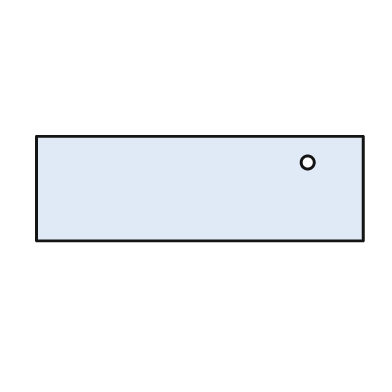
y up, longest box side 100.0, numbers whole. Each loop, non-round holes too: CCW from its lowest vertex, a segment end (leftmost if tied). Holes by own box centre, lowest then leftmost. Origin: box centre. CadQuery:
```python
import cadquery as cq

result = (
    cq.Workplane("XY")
    .moveTo(-50.0, -16.0)
    .lineTo(50.0, -16.0)
    .lineTo(50.0, 16.0)
    .lineTo(-50.0, 16.0)
    .close()
    .moveTo(33.0, 8.0)
    .circle(2.0)
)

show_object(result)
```